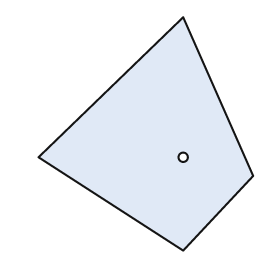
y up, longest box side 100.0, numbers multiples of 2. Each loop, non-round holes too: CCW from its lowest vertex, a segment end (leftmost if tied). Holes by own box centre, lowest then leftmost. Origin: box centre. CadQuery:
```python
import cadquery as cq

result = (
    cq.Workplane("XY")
    .moveTo(16.0, -50.0)
    .lineTo(46.0, -18.0)
    .lineTo(16.0, 50.0)
    .lineTo(-46.0, -10.0)
    .close()
    .moveTo(16.0, -10.0)
    .circle(2.0)
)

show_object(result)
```